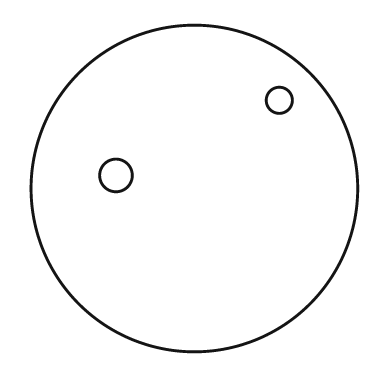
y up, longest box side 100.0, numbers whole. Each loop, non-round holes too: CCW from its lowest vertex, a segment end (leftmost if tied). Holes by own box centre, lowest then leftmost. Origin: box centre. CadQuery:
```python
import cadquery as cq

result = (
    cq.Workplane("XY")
    .moveTo(0.0, 0.0)
    .circle(50.0)
    .moveTo(-24.0, 4.0)
    .circle(5.0)
    .moveTo(26.0, 27.0)
    .circle(4.0)
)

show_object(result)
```